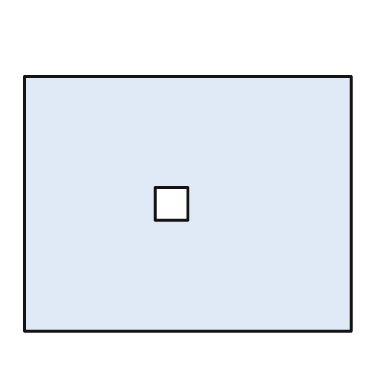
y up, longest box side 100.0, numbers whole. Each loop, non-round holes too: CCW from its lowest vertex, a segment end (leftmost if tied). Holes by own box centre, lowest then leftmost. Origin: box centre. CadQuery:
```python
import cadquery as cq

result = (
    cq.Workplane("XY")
    .moveTo(-50.0, -39.0)
    .lineTo(50.0, -39.0)
    .lineTo(50.0, 39.0)
    .lineTo(-50.0, 39.0)
    .close()
    .moveTo(-10.0, -5.0)
    .lineTo(0.0, -5.0)
    .lineTo(0.0, 5.0)
    .lineTo(-10.0, 5.0)
    .close()
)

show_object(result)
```